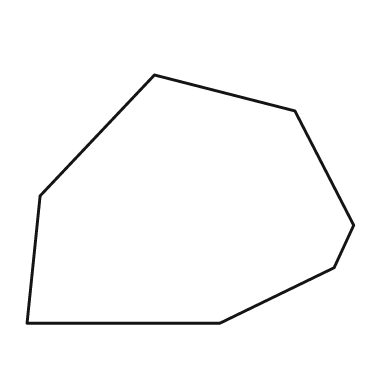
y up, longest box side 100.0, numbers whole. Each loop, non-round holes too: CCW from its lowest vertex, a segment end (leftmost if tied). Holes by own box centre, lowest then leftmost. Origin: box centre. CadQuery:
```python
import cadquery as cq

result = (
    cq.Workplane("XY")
    .moveTo(-50.0, -38.0)
    .lineTo(9.0, -38.0)
    .lineTo(44.0, -21.0)
    .lineTo(50.0, -8.0)
    .lineTo(32.0, 27.0)
    .lineTo(-11.0, 38.0)
    .lineTo(-46.0, 1.0)
    .close()
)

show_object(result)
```